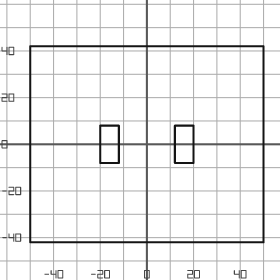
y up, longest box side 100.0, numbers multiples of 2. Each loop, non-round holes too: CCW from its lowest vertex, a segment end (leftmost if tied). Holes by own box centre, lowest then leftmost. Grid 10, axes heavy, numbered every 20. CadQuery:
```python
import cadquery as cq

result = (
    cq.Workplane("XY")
    .moveTo(-50.0, -42.0)
    .lineTo(50.0, -42.0)
    .lineTo(50.0, 42.0)
    .lineTo(-50.0, 42.0)
    .close()
    .moveTo(-20.0, -8.0)
    .lineTo(-12.0, -8.0)
    .lineTo(-12.0, 8.0)
    .lineTo(-20.0, 8.0)
    .close()
    .moveTo(12.0, -8.0)
    .lineTo(20.0, -8.0)
    .lineTo(20.0, 8.0)
    .lineTo(12.0, 8.0)
    .close()
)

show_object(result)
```